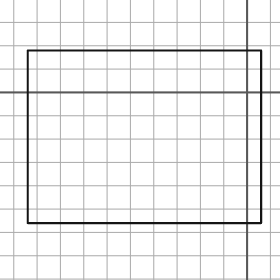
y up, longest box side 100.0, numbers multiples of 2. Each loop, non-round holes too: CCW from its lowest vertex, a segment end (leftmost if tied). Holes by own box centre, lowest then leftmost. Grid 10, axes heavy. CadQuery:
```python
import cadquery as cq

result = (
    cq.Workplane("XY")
    .moveTo(-94.0, -56.0)
    .lineTo(6.0, -56.0)
    .lineTo(6.0, 18.0)
    .lineTo(-94.0, 18.0)
    .close()
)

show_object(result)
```